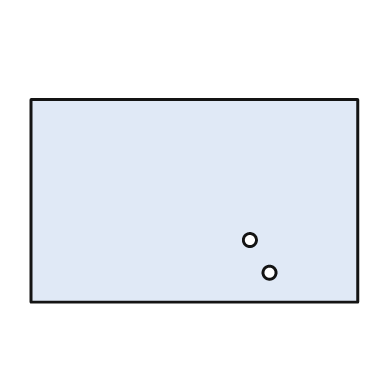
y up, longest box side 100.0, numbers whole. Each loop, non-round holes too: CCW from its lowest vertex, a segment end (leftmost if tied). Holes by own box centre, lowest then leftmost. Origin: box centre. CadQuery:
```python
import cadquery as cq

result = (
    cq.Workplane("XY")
    .moveTo(-50.0, -31.0)
    .lineTo(50.0, -31.0)
    .lineTo(50.0, 31.0)
    .lineTo(-50.0, 31.0)
    .close()
    .moveTo(23.0, -22.0)
    .circle(2.0)
    .moveTo(17.0, -12.0)
    .circle(2.0)
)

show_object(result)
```